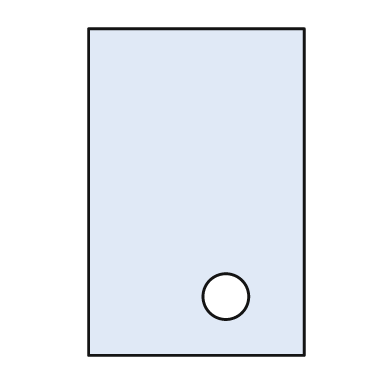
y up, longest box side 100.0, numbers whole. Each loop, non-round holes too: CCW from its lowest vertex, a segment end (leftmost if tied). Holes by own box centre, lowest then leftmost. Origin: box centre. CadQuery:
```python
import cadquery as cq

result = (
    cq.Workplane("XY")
    .moveTo(-33.0, -50.0)
    .lineTo(33.0, -50.0)
    .lineTo(33.0, 50.0)
    .lineTo(-33.0, 50.0)
    .close()
    .moveTo(9.0, -32.0)
    .circle(7.0)
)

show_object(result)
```